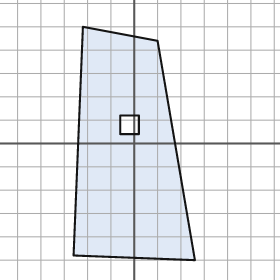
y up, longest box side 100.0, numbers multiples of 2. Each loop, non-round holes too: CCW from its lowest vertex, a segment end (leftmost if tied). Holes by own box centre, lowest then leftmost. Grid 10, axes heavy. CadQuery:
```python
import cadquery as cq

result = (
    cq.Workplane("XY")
    .moveTo(26.0, -50.0)
    .lineTo(10.0, 44.0)
    .lineTo(-22.0, 50.0)
    .lineTo(-26.0, -48.0)
    .close()
    .moveTo(-6.0, 4.0)
    .lineTo(2.0, 4.0)
    .lineTo(2.0, 12.0)
    .lineTo(-6.0, 12.0)
    .close()
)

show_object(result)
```